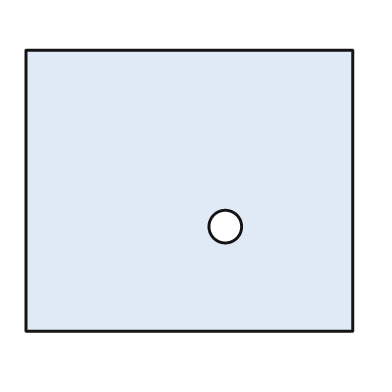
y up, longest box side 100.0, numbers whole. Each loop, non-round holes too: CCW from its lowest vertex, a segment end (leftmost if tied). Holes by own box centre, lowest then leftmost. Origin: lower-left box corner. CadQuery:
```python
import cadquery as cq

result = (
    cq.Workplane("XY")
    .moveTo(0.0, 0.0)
    .lineTo(100.0, 0.0)
    .lineTo(100.0, 86.0)
    .lineTo(0.0, 86.0)
    .close()
    .moveTo(61.0, 32.0)
    .circle(5.0)
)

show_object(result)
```